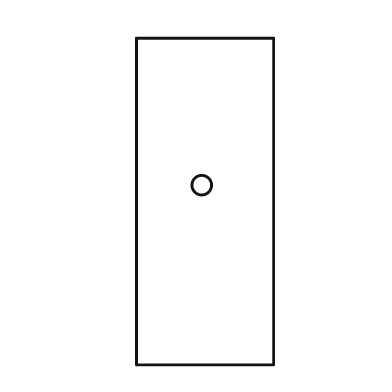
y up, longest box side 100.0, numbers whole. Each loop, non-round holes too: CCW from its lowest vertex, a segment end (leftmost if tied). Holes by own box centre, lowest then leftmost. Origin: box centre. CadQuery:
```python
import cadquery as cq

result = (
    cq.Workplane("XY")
    .moveTo(-21.0, -50.0)
    .lineTo(21.0, -50.0)
    .lineTo(21.0, 50.0)
    .lineTo(-21.0, 50.0)
    .close()
    .moveTo(-1.0, 5.0)
    .circle(3.0)
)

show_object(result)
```